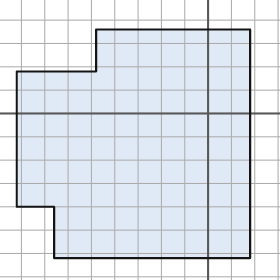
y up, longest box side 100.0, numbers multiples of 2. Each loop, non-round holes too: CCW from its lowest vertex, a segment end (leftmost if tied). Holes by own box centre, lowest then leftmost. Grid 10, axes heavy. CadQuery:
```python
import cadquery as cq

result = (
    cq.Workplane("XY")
    .moveTo(-66.0, -62.0)
    .lineTo(18.0, -62.0)
    .lineTo(18.0, 36.0)
    .lineTo(-48.0, 36.0)
    .lineTo(-48.0, 18.0)
    .lineTo(-82.0, 18.0)
    .lineTo(-82.0, -40.0)
    .lineTo(-66.0, -40.0)
    .close()
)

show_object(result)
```